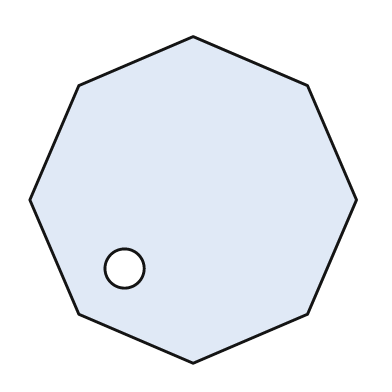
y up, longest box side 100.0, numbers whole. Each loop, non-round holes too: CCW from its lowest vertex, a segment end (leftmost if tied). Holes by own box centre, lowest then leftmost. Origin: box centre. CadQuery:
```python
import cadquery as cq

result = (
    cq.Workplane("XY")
    .moveTo(0.0, -50.0)
    .lineTo(35.0, -35.0)
    .lineTo(50.0, 0.0)
    .lineTo(35.0, 35.0)
    .lineTo(0.0, 50.0)
    .lineTo(-35.0, 35.0)
    .lineTo(-50.0, 0.0)
    .lineTo(-35.0, -35.0)
    .close()
    .moveTo(-21.0, -21.0)
    .circle(6.0)
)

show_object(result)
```